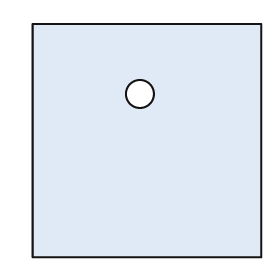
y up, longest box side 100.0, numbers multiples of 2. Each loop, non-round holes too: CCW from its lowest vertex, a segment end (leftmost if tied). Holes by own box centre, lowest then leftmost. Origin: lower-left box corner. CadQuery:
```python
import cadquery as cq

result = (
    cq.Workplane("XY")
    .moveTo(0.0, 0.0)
    .lineTo(98.0, 0.0)
    .lineTo(98.0, 100.0)
    .lineTo(0.0, 100.0)
    .close()
    .moveTo(46.0, 70.0)
    .circle(6.0)
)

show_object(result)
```